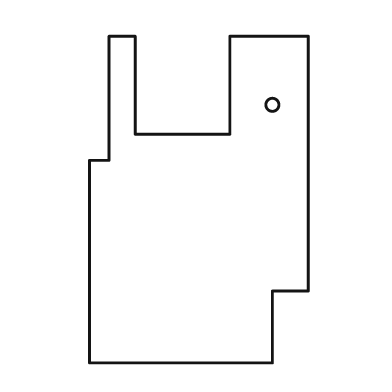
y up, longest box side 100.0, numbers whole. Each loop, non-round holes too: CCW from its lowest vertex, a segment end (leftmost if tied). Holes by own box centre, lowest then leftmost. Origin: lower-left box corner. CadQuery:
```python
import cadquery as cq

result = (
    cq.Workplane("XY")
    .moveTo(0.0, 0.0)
    .lineTo(56.0, 0.0)
    .lineTo(56.0, 22.0)
    .lineTo(67.0, 22.0)
    .lineTo(67.0, 100.0)
    .lineTo(43.0, 100.0)
    .lineTo(43.0, 70.0)
    .lineTo(14.0, 70.0)
    .lineTo(14.0, 100.0)
    .lineTo(6.0, 100.0)
    .lineTo(6.0, 62.0)
    .lineTo(0.0, 62.0)
    .close()
    .moveTo(56.0, 79.0)
    .circle(2.0)
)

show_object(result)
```